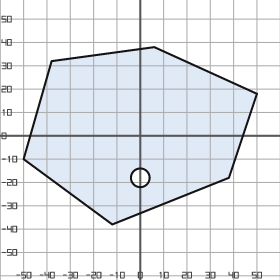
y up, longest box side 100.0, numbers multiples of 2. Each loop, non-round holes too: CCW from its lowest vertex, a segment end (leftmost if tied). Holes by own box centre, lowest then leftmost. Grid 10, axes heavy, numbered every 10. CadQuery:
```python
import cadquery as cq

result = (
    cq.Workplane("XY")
    .moveTo(-12.0, -38.0)
    .lineTo(38.0, -18.0)
    .lineTo(50.0, 18.0)
    .lineTo(6.0, 38.0)
    .lineTo(-38.0, 32.0)
    .lineTo(-50.0, -10.0)
    .close()
    .moveTo(0.0, -18.0)
    .circle(4.0)
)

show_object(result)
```